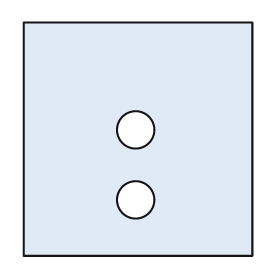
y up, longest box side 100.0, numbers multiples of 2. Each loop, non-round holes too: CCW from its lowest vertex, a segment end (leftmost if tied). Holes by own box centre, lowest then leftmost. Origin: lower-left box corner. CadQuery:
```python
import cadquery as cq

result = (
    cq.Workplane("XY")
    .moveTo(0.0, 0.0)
    .lineTo(98.0, 0.0)
    .lineTo(98.0, 100.0)
    .lineTo(0.0, 100.0)
    .close()
    .moveTo(48.0, 24.0)
    .circle(8.0)
    .moveTo(48.0, 54.0)
    .circle(8.0)
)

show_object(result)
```